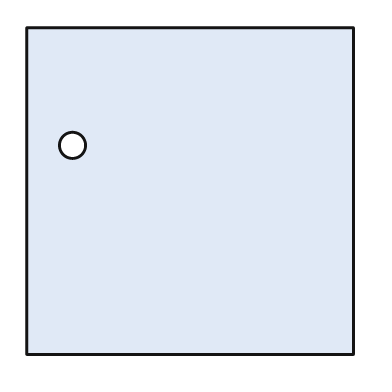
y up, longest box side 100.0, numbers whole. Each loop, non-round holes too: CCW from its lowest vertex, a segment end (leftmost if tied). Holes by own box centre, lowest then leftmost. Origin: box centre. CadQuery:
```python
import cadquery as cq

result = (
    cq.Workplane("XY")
    .moveTo(-50.0, -50.0)
    .lineTo(50.0, -50.0)
    .lineTo(50.0, 50.0)
    .lineTo(-50.0, 50.0)
    .close()
    .moveTo(-36.0, 14.0)
    .circle(4.0)
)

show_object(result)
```